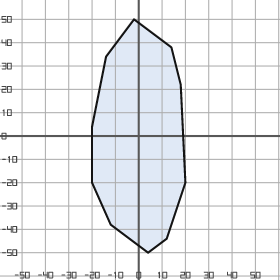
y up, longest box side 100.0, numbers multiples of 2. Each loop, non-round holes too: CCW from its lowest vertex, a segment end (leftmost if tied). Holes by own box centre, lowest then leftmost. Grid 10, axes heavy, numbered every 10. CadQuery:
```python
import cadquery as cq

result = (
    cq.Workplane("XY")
    .moveTo(4.0, -50.0)
    .lineTo(12.0, -44.0)
    .lineTo(20.0, -20.0)
    .lineTo(18.0, 22.0)
    .lineTo(14.0, 38.0)
    .lineTo(-2.0, 50.0)
    .lineTo(-14.0, 34.0)
    .lineTo(-20.0, 4.0)
    .lineTo(-20.0, -20.0)
    .lineTo(-12.0, -38.0)
    .close()
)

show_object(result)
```